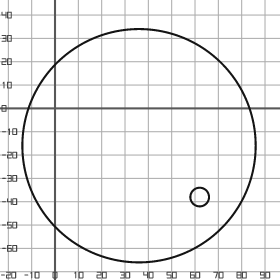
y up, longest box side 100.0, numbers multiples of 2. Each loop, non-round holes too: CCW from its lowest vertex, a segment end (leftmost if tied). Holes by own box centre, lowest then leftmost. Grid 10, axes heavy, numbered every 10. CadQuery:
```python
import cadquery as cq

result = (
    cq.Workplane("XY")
    .moveTo(36.0, -16.0)
    .circle(50.0)
    .moveTo(62.0, -38.0)
    .circle(4.0)
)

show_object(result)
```